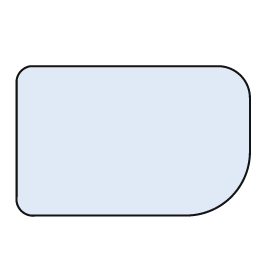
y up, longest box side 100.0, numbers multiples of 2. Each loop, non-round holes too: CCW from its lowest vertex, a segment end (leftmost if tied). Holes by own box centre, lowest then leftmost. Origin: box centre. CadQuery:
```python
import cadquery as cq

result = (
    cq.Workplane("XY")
    .moveTo(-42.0, -32.0)
    .lineTo(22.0, -32.0)
    .threePointArc((42.0, -24.0), (50.0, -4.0))
    .lineTo(50.0, 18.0)
    .threePointArc((46.0, 28.0), (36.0, 32.0))
    .lineTo(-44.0, 32.0)
    .threePointArc((-48.0, 30.0), (-50.0, 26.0))
    .lineTo(-50.0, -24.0)
    .threePointArc((-48.0, -30.0), (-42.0, -32.0))
    .close()
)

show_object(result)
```